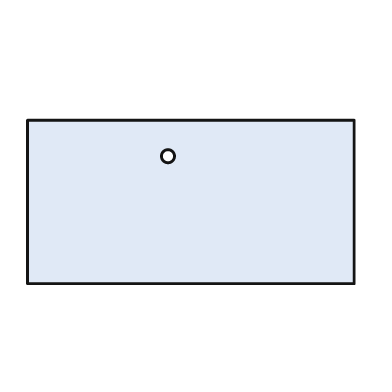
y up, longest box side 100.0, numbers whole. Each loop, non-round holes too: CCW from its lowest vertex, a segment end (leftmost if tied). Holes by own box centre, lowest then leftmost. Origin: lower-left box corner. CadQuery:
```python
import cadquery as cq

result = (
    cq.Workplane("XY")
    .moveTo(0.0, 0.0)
    .lineTo(100.0, 0.0)
    .lineTo(100.0, 50.0)
    .lineTo(0.0, 50.0)
    .close()
    .moveTo(43.0, 39.0)
    .circle(2.0)
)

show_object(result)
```